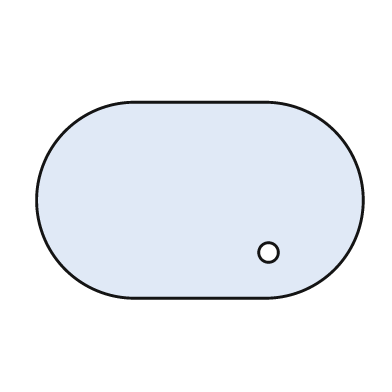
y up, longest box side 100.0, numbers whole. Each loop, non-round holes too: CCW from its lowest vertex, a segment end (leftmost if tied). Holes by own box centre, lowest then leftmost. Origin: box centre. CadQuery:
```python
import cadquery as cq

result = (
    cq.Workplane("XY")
    .moveTo(-20.0, -30.0)
    .lineTo(20.0, -30.0)
    .threePointArc((50.0, 0.0), (20.0, 30.0))
    .lineTo(-20.0, 30.0)
    .threePointArc((-50.0, 0.0), (-20.0, -30.0))
    .close()
    .moveTo(21.0, -16.0)
    .circle(3.0)
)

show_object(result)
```